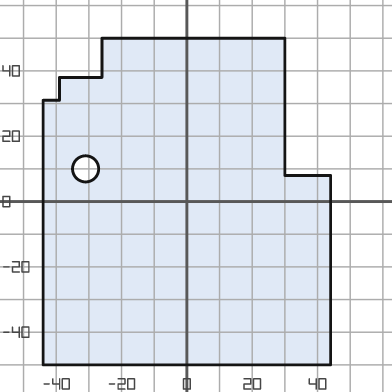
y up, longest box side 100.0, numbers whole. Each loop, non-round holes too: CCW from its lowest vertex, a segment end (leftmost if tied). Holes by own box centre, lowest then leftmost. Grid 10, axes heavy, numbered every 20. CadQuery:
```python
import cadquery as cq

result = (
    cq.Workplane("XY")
    .moveTo(-44.0, -50.0)
    .lineTo(44.0, -50.0)
    .lineTo(44.0, 8.0)
    .lineTo(30.0, 8.0)
    .lineTo(30.0, 50.0)
    .lineTo(-26.0, 50.0)
    .lineTo(-26.0, 38.0)
    .lineTo(-39.0, 38.0)
    .lineTo(-39.0, 31.0)
    .lineTo(-44.0, 31.0)
    .close()
    .moveTo(-31.0, 10.0)
    .circle(4.0)
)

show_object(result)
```